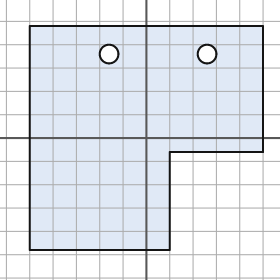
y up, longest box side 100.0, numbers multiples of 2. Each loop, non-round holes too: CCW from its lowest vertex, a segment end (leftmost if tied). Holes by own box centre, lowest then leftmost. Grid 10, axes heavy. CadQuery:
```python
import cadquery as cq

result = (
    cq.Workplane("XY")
    .moveTo(-50.0, -48.0)
    .lineTo(10.0, -48.0)
    .lineTo(10.0, -6.0)
    .lineTo(50.0, -6.0)
    .lineTo(50.0, 48.0)
    .lineTo(-50.0, 48.0)
    .close()
    .moveTo(-16.0, 36.0)
    .circle(4.0)
    .moveTo(26.0, 36.0)
    .circle(4.0)
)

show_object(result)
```